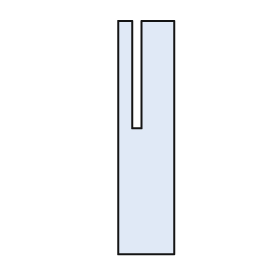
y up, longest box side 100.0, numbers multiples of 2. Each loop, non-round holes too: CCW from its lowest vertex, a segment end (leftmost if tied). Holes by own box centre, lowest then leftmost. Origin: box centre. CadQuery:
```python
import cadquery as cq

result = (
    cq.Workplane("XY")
    .moveTo(-12.0, -50.0)
    .lineTo(12.0, -50.0)
    .lineTo(12.0, 50.0)
    .lineTo(-2.0, 50.0)
    .lineTo(-2.0, 4.0)
    .lineTo(-6.0, 4.0)
    .lineTo(-6.0, 50.0)
    .lineTo(-12.0, 50.0)
    .close()
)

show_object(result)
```